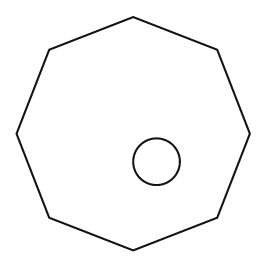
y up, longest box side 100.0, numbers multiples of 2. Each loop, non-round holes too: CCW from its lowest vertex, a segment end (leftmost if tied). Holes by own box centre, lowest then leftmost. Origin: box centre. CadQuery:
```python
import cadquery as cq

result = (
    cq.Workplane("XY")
    .moveTo(0.0, -50.0)
    .lineTo(36.0, -36.0)
    .lineTo(50.0, 0.0)
    .lineTo(36.0, 36.0)
    .lineTo(0.0, 50.0)
    .lineTo(-36.0, 36.0)
    .lineTo(-50.0, 0.0)
    .lineTo(-36.0, -36.0)
    .close()
    .moveTo(10.0, -12.0)
    .circle(10.0)
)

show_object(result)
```